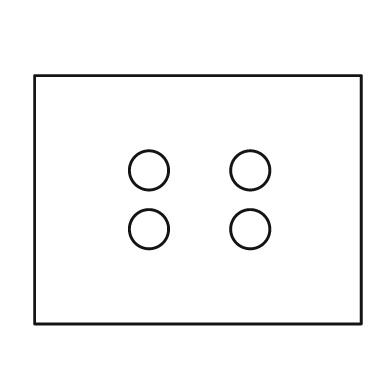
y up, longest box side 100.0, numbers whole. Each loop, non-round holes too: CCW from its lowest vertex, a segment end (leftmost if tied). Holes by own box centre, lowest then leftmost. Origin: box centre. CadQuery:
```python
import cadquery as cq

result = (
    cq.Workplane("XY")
    .moveTo(-50.0, -38.0)
    .lineTo(50.0, -38.0)
    .lineTo(50.0, 38.0)
    .lineTo(-50.0, 38.0)
    .close()
    .moveTo(-15.0, -9.0)
    .circle(6.0)
    .moveTo(16.0, -9.0)
    .circle(6.0)
    .moveTo(-15.0, 9.0)
    .circle(6.0)
    .moveTo(16.0, 9.0)
    .circle(6.0)
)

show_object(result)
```